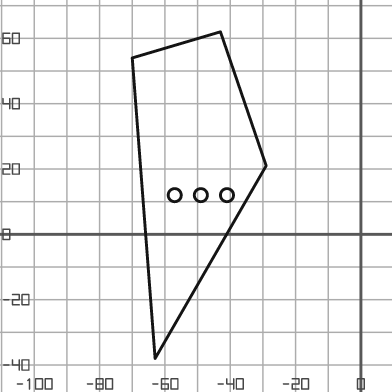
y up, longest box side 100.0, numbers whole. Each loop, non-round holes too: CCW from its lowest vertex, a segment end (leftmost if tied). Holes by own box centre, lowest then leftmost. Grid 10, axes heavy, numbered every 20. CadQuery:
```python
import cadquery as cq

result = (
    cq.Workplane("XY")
    .moveTo(-63.0, -38.0)
    .lineTo(-29.0, 21.0)
    .lineTo(-43.0, 62.0)
    .lineTo(-70.0, 54.0)
    .close()
    .moveTo(-57.0, 12.0)
    .circle(2.0)
    .moveTo(-49.0, 12.0)
    .circle(2.0)
    .moveTo(-41.0, 12.0)
    .circle(2.0)
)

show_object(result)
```